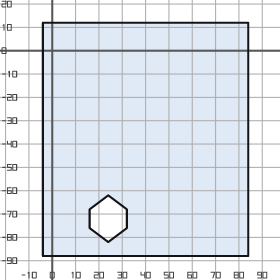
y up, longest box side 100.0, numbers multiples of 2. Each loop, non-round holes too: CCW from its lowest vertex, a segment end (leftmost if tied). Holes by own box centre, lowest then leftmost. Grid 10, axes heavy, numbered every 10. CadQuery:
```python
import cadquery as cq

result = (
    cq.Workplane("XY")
    .moveTo(-4.0, -88.0)
    .lineTo(84.0, -88.0)
    .lineTo(84.0, 12.0)
    .lineTo(-4.0, 12.0)
    .close()
    .moveTo(24.0, -82.0)
    .lineTo(32.0, -76.0)
    .lineTo(32.0, -68.0)
    .lineTo(24.0, -62.0)
    .lineTo(16.0, -68.0)
    .lineTo(16.0, -76.0)
    .close()
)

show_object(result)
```